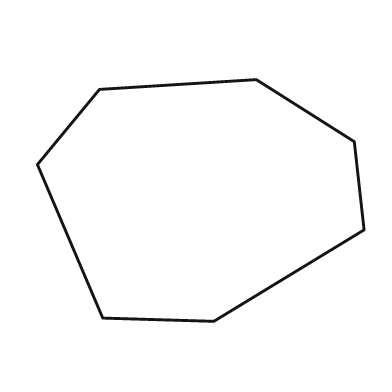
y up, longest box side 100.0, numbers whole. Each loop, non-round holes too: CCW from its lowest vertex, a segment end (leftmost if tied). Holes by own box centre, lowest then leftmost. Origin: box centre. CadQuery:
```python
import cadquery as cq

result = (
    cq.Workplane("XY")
    .moveTo(4.0, -37.0)
    .lineTo(50.0, -9.0)
    .lineTo(47.0, 18.0)
    .lineTo(17.0, 37.0)
    .lineTo(-31.0, 34.0)
    .lineTo(-50.0, 11.0)
    .lineTo(-30.0, -36.0)
    .close()
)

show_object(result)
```